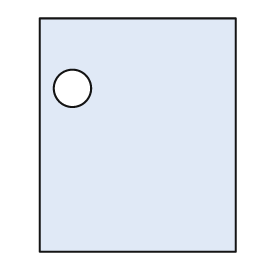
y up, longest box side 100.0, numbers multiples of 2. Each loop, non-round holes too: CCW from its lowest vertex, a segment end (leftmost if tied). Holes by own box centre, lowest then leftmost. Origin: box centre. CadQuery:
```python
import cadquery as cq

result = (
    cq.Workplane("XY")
    .moveTo(-42.0, -50.0)
    .lineTo(42.0, -50.0)
    .lineTo(42.0, 50.0)
    .lineTo(-42.0, 50.0)
    .close()
    .moveTo(-28.0, 20.0)
    .circle(8.0)
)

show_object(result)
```